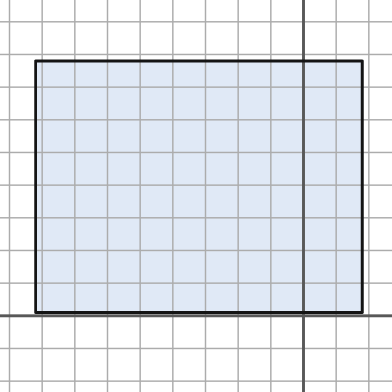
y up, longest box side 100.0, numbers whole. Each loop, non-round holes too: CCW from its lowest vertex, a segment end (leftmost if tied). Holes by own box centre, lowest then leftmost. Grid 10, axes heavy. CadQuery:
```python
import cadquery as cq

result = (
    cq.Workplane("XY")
    .moveTo(-82.0, 1.0)
    .lineTo(18.0, 1.0)
    .lineTo(18.0, 78.0)
    .lineTo(-82.0, 78.0)
    .close()
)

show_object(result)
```